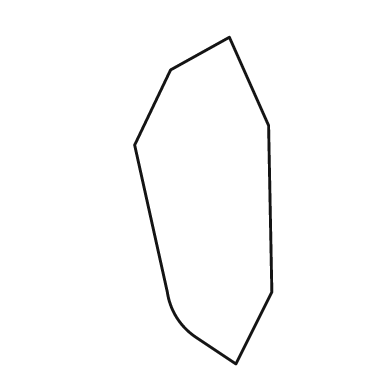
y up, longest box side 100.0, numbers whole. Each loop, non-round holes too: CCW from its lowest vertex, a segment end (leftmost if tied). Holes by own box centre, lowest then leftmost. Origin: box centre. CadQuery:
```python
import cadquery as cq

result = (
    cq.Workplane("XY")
    .moveTo(10.0, -50.0)
    .lineTo(21.0, -28.0)
    .lineTo(20.0, 23.0)
    .lineTo(8.0, 50.0)
    .lineTo(-10.0, 40.0)
    .lineTo(-21.0, 17.0)
    .lineTo(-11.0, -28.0)
    .threePointArc((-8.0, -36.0), (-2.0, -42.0))
    .close()
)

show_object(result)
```